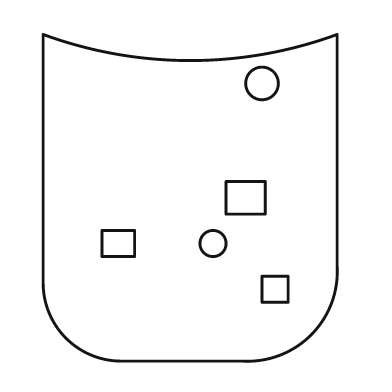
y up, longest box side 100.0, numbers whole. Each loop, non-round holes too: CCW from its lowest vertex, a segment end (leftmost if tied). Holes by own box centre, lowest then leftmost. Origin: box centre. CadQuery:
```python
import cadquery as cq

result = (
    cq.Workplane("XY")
    .moveTo(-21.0, -50.0)
    .lineTo(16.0, -50.0)
    .threePointArc((37.0, -42.0), (45.0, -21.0))
    .lineTo(45.0, 50.0)
    .threePointArc((0.0, 42.0), (-45.0, 50.0))
    .lineTo(-45.0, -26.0)
    .threePointArc((-38.0, -43.0), (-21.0, -50.0))
    .close()
    .moveTo(22.0, -32.0)
    .lineTo(30.0, -32.0)
    .lineTo(30.0, -24.0)
    .lineTo(22.0, -24.0)
    .close()
    .moveTo(-27.0, -18.0)
    .lineTo(-17.0, -18.0)
    .lineTo(-17.0, -10.0)
    .lineTo(-27.0, -10.0)
    .close()
    .moveTo(7.0, -14.0)
    .circle(4.0)
    .moveTo(11.0, -5.0)
    .lineTo(23.0, -5.0)
    .lineTo(23.0, 5.0)
    .lineTo(11.0, 5.0)
    .close()
    .moveTo(22.0, 35.0)
    .circle(5.0)
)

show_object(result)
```